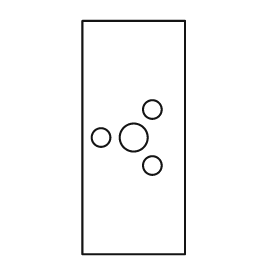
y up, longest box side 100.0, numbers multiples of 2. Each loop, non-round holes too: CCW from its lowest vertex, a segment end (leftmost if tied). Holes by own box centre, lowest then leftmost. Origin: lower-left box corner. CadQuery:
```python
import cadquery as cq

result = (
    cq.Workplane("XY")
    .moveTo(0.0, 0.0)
    .lineTo(44.0, 0.0)
    .lineTo(44.0, 100.0)
    .lineTo(0.0, 100.0)
    .close()
    .moveTo(30.0, 38.0)
    .circle(4.0)
    .moveTo(8.0, 50.0)
    .circle(4.0)
    .moveTo(22.0, 50.0)
    .circle(6.0)
    .moveTo(30.0, 62.0)
    .circle(4.0)
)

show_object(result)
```